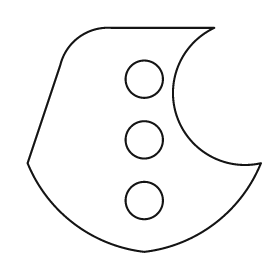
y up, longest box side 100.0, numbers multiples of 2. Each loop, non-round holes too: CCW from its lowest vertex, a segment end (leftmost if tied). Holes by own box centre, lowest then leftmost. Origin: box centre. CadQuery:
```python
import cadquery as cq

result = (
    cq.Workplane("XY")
    .moveTo(0.0, -48.0)
    .threePointArc((30.0, -36.0), (50.0, -10.0))
    .threePointArc((14.0, 10.0), (30.0, 48.0))
    .lineTo(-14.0, 48.0)
    .threePointArc((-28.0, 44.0), (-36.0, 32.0))
    .lineTo(-50.0, -10.0)
    .threePointArc((-30.0, -36.0), (0.0, -48.0))
    .close()
    .moveTo(0.0, -26.0)
    .circle(8.0)
    .moveTo(0.0, 0.0)
    .circle(8.0)
    .moveTo(0.0, 26.0)
    .circle(8.0)
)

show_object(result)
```